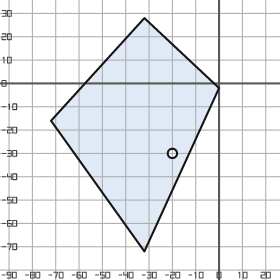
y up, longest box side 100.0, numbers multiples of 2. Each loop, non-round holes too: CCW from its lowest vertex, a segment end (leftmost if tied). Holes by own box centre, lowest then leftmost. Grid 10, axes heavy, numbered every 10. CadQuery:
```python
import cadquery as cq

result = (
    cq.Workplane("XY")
    .moveTo(-32.0, -72.0)
    .lineTo(0.0, -2.0)
    .lineTo(-32.0, 28.0)
    .lineTo(-72.0, -16.0)
    .close()
    .moveTo(-20.0, -30.0)
    .circle(2.0)
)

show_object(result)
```